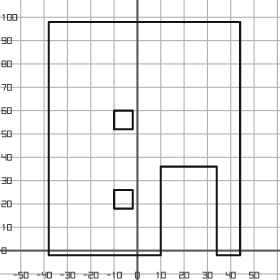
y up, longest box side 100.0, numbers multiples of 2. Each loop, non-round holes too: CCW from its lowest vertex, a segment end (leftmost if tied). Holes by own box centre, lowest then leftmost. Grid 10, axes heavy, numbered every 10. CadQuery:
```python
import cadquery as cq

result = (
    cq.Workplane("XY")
    .moveTo(-38.0, -2.0)
    .lineTo(10.0, -2.0)
    .lineTo(10.0, 36.0)
    .lineTo(34.0, 36.0)
    .lineTo(34.0, -2.0)
    .lineTo(44.0, -2.0)
    .lineTo(44.0, 98.0)
    .lineTo(-38.0, 98.0)
    .close()
    .moveTo(-10.0, 18.0)
    .lineTo(-2.0, 18.0)
    .lineTo(-2.0, 26.0)
    .lineTo(-10.0, 26.0)
    .close()
    .moveTo(-10.0, 52.0)
    .lineTo(-2.0, 52.0)
    .lineTo(-2.0, 60.0)
    .lineTo(-10.0, 60.0)
    .close()
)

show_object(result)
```